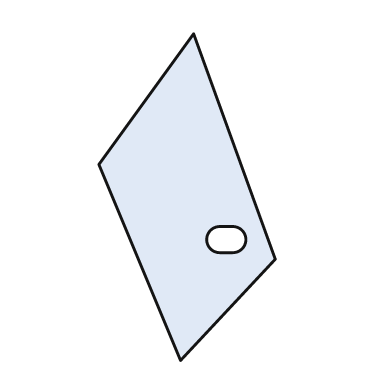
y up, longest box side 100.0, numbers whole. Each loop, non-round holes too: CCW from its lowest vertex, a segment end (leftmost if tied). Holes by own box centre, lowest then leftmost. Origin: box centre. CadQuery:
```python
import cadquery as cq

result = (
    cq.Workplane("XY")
    .moveTo(-2.0, -50.0)
    .lineTo(27.0, -19.0)
    .lineTo(2.0, 50.0)
    .lineTo(-27.0, 10.0)
    .close()
    .moveTo(10.0, -17.0)
    .lineTo(14.0, -17.0)
    .threePointArc((18.0, -13.0), (14.0, -9.0))
    .lineTo(10.0, -9.0)
    .threePointArc((6.0, -13.0), (10.0, -17.0))
    .close()
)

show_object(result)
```